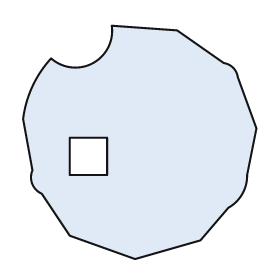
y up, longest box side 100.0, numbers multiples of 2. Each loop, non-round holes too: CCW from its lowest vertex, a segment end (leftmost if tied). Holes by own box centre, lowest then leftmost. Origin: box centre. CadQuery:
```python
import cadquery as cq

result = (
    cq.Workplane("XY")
    .moveTo(-2.0, -50.0)
    .lineTo(26.0, -42.0)
    .lineTo(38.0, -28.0)
    .threePointArc((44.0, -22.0), (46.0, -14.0))
    .lineTo(50.0, 6.0)
    .lineTo(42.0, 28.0)
    .threePointArc((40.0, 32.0), (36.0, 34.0))
    .lineTo(16.0, 48.0)
    .lineTo(-12.0, 50.0)
    .threePointArc((-20.0, 34.0), (-38.0, 36.0))
    .threePointArc((-46.0, 24.0), (-50.0, 10.0))
    .lineTo(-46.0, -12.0)
    .threePointArc((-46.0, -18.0), (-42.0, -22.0))
    .lineTo(-30.0, -40.0)
    .close()
    .moveTo(-30.0, -14.0)
    .lineTo(-14.0, -14.0)
    .lineTo(-14.0, 2.0)
    .lineTo(-30.0, 2.0)
    .close()
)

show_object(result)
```